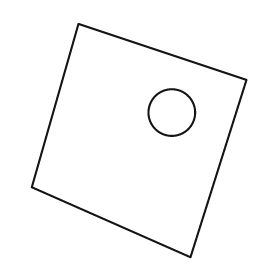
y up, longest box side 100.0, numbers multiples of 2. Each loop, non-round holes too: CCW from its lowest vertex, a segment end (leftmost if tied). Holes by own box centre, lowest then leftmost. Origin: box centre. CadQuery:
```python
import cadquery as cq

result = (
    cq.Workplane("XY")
    .moveTo(22.0, -50.0)
    .lineTo(46.0, 26.0)
    .lineTo(-26.0, 50.0)
    .lineTo(-46.0, -20.0)
    .close()
    .moveTo(14.0, 12.0)
    .circle(10.0)
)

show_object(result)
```